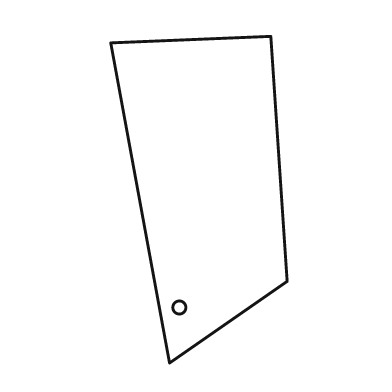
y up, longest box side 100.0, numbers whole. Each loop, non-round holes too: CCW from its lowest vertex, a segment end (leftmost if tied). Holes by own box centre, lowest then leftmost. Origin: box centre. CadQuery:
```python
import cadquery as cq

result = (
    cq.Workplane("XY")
    .moveTo(-9.0, -50.0)
    .lineTo(27.0, -25.0)
    .lineTo(22.0, 50.0)
    .lineTo(-27.0, 48.0)
    .close()
    .moveTo(-6.0, -33.0)
    .circle(2.0)
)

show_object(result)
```